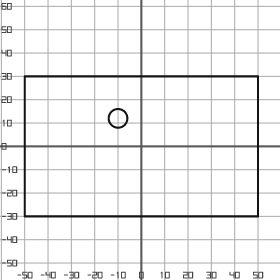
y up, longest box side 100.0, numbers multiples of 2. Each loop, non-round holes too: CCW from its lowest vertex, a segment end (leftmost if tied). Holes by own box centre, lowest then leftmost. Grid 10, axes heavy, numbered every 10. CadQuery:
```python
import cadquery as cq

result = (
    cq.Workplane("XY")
    .moveTo(-50.0, -30.0)
    .lineTo(50.0, -30.0)
    .lineTo(50.0, 30.0)
    .lineTo(-50.0, 30.0)
    .close()
    .moveTo(-10.0, 12.0)
    .circle(4.0)
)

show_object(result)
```